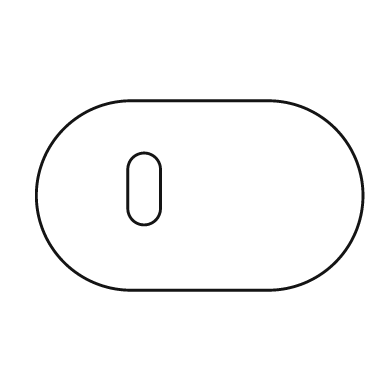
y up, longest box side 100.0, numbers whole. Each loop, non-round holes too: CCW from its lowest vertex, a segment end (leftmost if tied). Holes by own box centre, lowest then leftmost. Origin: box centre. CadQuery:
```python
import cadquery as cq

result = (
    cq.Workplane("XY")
    .moveTo(-21.0, -29.0)
    .lineTo(21.0, -29.0)
    .threePointArc((50.0, 0.0), (21.0, 29.0))
    .lineTo(-21.0, 29.0)
    .threePointArc((-50.0, 0.0), (-21.0, -29.0))
    .close()
    .moveTo(-22.0, -4.0)
    .threePointArc((-17.0, -9.0), (-12.0, -4.0))
    .lineTo(-12.0, 8.0)
    .threePointArc((-17.0, 13.0), (-22.0, 8.0))
    .close()
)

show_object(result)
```